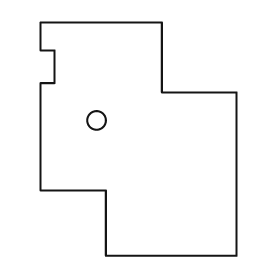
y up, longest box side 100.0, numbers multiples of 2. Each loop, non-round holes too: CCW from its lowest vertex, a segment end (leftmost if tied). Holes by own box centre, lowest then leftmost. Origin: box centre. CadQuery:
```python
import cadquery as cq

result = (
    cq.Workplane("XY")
    .moveTo(-14.0, -50.0)
    .lineTo(42.0, -50.0)
    .lineTo(42.0, 20.0)
    .lineTo(10.0, 20.0)
    .lineTo(10.0, 50.0)
    .lineTo(-42.0, 50.0)
    .lineTo(-42.0, 38.0)
    .lineTo(-36.0, 38.0)
    .lineTo(-36.0, 24.0)
    .lineTo(-42.0, 24.0)
    .lineTo(-42.0, -22.0)
    .lineTo(-14.0, -22.0)
    .close()
    .moveTo(-18.0, 8.0)
    .circle(4.0)
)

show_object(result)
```